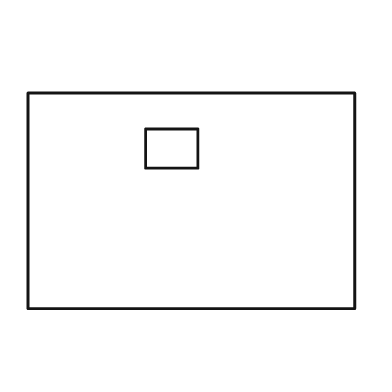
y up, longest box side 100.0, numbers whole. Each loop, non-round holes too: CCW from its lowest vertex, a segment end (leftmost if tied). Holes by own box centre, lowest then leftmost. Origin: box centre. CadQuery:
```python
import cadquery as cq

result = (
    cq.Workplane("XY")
    .moveTo(-50.0, -33.0)
    .lineTo(50.0, -33.0)
    .lineTo(50.0, 33.0)
    .lineTo(-50.0, 33.0)
    .close()
    .moveTo(-14.0, 10.0)
    .lineTo(2.0, 10.0)
    .lineTo(2.0, 22.0)
    .lineTo(-14.0, 22.0)
    .close()
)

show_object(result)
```